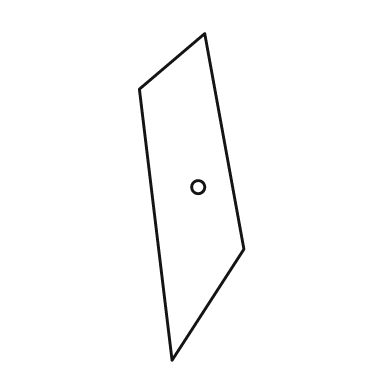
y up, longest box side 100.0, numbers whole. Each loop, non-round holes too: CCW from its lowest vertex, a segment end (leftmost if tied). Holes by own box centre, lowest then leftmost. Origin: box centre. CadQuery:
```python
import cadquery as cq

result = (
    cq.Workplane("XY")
    .moveTo(-6.0, -50.0)
    .lineTo(16.0, -16.0)
    .lineTo(4.0, 50.0)
    .lineTo(-16.0, 33.0)
    .close()
    .moveTo(2.0, 3.0)
    .circle(2.0)
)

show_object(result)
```